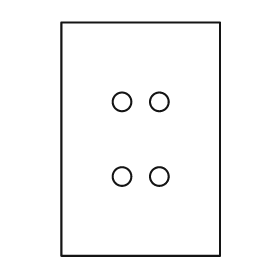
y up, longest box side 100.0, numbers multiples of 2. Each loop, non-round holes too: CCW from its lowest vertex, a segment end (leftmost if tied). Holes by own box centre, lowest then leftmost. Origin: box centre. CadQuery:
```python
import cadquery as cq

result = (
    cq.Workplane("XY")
    .moveTo(-34.0, -50.0)
    .lineTo(34.0, -50.0)
    .lineTo(34.0, 50.0)
    .lineTo(-34.0, 50.0)
    .close()
    .moveTo(-8.0, -16.0)
    .circle(4.0)
    .moveTo(8.0, -16.0)
    .circle(4.0)
    .moveTo(-8.0, 16.0)
    .circle(4.0)
    .moveTo(8.0, 16.0)
    .circle(4.0)
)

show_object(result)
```